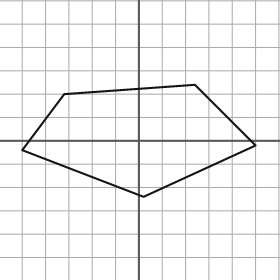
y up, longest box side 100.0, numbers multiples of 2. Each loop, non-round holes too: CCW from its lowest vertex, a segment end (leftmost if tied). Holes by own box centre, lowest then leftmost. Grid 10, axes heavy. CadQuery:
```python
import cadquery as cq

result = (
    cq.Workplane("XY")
    .moveTo(2.0, -24.0)
    .lineTo(50.0, -2.0)
    .lineTo(24.0, 24.0)
    .lineTo(-32.0, 20.0)
    .lineTo(-50.0, -4.0)
    .close()
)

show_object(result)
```